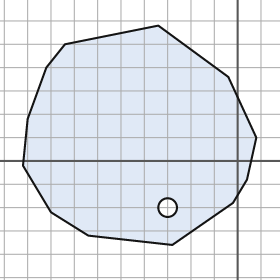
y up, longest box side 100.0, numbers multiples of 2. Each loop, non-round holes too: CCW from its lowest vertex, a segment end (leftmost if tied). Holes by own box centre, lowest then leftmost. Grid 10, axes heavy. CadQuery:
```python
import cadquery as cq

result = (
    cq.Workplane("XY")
    .moveTo(-28.0, -36.0)
    .lineTo(-2.0, -18.0)
    .lineTo(4.0, -8.0)
    .lineTo(8.0, 10.0)
    .lineTo(-4.0, 36.0)
    .lineTo(-34.0, 58.0)
    .lineTo(-74.0, 50.0)
    .lineTo(-82.0, 40.0)
    .lineTo(-90.0, 18.0)
    .lineTo(-92.0, -2.0)
    .lineTo(-80.0, -22.0)
    .lineTo(-64.0, -32.0)
    .close()
    .moveTo(-30.0, -20.0)
    .circle(4.0)
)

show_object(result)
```